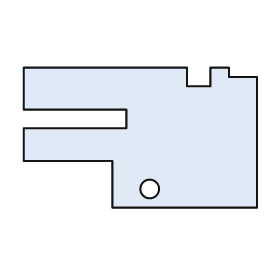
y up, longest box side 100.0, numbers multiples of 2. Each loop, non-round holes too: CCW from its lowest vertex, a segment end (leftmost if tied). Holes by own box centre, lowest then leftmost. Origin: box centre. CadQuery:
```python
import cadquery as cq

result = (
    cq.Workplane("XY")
    .moveTo(-12.0, -30.0)
    .lineTo(50.0, -30.0)
    .lineTo(50.0, 26.0)
    .lineTo(38.0, 26.0)
    .lineTo(38.0, 30.0)
    .lineTo(30.0, 30.0)
    .lineTo(30.0, 22.0)
    .lineTo(20.0, 22.0)
    .lineTo(20.0, 30.0)
    .lineTo(-50.0, 30.0)
    .lineTo(-50.0, 12.0)
    .lineTo(-6.0, 12.0)
    .lineTo(-6.0, 4.0)
    .lineTo(-50.0, 4.0)
    .lineTo(-50.0, -10.0)
    .lineTo(-12.0, -10.0)
    .close()
    .moveTo(4.0, -22.0)
    .circle(4.0)
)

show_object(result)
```